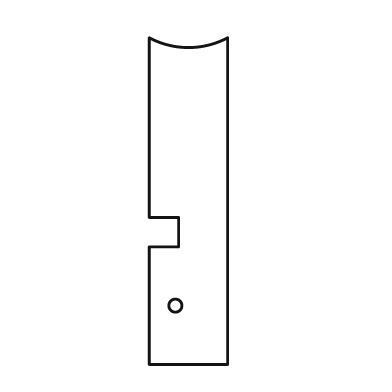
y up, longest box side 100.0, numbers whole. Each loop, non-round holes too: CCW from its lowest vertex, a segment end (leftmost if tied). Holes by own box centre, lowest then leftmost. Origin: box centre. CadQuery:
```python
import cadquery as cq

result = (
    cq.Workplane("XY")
    .moveTo(-12.0, -50.0)
    .lineTo(12.0, -50.0)
    .lineTo(12.0, 50.0)
    .threePointArc((0.0, 47.0), (-12.0, 50.0))
    .lineTo(-12.0, -5.0)
    .lineTo(-3.0, -5.0)
    .lineTo(-3.0, -14.0)
    .lineTo(-12.0, -14.0)
    .close()
    .moveTo(-4.0, -32.0)
    .circle(2.0)
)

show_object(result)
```